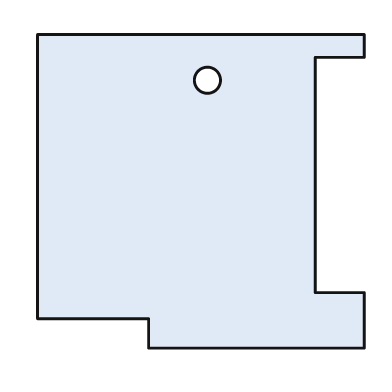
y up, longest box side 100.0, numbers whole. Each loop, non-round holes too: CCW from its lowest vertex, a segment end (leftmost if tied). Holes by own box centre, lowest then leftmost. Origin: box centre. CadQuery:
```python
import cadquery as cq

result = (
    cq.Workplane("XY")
    .moveTo(-16.0, -48.0)
    .lineTo(50.0, -48.0)
    .lineTo(50.0, -31.0)
    .lineTo(35.0, -31.0)
    .lineTo(35.0, 41.0)
    .lineTo(50.0, 41.0)
    .lineTo(50.0, 48.0)
    .lineTo(-50.0, 48.0)
    .lineTo(-50.0, -39.0)
    .lineTo(-16.0, -39.0)
    .close()
    .moveTo(2.0, 34.0)
    .circle(4.0)
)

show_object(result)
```